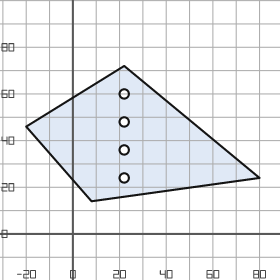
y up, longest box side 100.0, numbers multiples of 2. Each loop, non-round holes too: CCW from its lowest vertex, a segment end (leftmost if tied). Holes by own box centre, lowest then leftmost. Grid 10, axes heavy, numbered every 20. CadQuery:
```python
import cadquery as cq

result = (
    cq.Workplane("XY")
    .moveTo(8.0, 14.0)
    .lineTo(80.0, 24.0)
    .lineTo(22.0, 72.0)
    .lineTo(-20.0, 46.0)
    .close()
    .moveTo(22.0, 24.0)
    .circle(2.0)
    .moveTo(22.0, 36.0)
    .circle(2.0)
    .moveTo(22.0, 48.0)
    .circle(2.0)
    .moveTo(22.0, 60.0)
    .circle(2.0)
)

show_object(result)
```